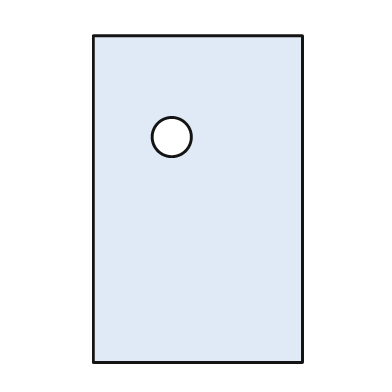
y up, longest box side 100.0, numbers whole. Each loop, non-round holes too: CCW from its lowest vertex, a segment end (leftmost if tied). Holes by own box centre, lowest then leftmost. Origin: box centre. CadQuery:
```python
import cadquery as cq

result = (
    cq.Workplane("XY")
    .moveTo(-32.0, -50.0)
    .lineTo(32.0, -50.0)
    .lineTo(32.0, 50.0)
    .lineTo(-32.0, 50.0)
    .close()
    .moveTo(-8.0, 19.0)
    .circle(6.0)
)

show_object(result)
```